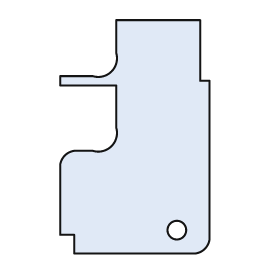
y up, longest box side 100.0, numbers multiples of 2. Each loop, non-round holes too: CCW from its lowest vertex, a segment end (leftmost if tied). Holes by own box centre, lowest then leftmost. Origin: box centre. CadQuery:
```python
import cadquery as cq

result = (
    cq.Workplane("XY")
    .moveTo(-26.0, -50.0)
    .lineTo(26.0, -50.0)
    .threePointArc((30.0, -48.0), (32.0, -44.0))
    .lineTo(32.0, 24.0)
    .lineTo(28.0, 24.0)
    .lineTo(28.0, 50.0)
    .lineTo(-8.0, 50.0)
    .lineTo(-8.0, 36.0)
    .threePointArc((-10.0, 28.0), (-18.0, 26.0))
    .lineTo(-32.0, 26.0)
    .lineTo(-32.0, 22.0)
    .lineTo(-8.0, 22.0)
    .lineTo(-8.0, 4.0)
    .threePointArc((-10.0, -4.0), (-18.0, -6.0))
    .lineTo(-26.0, -6.0)
    .threePointArc((-30.0, -8.0), (-32.0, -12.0))
    .lineTo(-32.0, -42.0)
    .lineTo(-26.0, -42.0)
    .close()
    .moveTo(18.0, -40.0)
    .circle(4.0)
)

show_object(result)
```